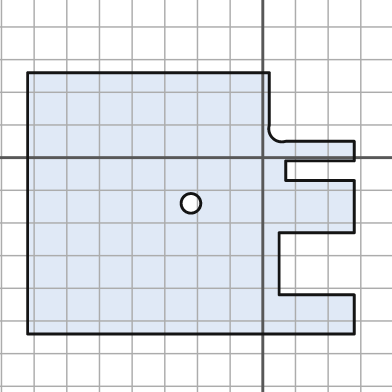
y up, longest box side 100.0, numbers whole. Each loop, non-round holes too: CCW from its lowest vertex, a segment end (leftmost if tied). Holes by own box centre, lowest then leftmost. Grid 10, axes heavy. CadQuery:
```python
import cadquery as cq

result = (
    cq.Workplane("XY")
    .moveTo(-72.0, -54.0)
    .lineTo(28.0, -54.0)
    .lineTo(28.0, -42.0)
    .lineTo(5.0, -42.0)
    .lineTo(5.0, -23.0)
    .lineTo(28.0, -23.0)
    .lineTo(28.0, -7.0)
    .lineTo(7.0, -7.0)
    .lineTo(7.0, -1.0)
    .lineTo(28.0, -1.0)
    .lineTo(28.0, 5.0)
    .lineTo(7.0, 5.0)
    .threePointArc((3.0, 6.0), (2.0, 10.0))
    .lineTo(2.0, 26.0)
    .lineTo(-72.0, 26.0)
    .close()
    .moveTo(-22.0, -14.0)
    .circle(3.0)
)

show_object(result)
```